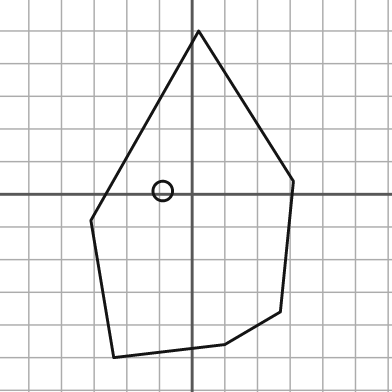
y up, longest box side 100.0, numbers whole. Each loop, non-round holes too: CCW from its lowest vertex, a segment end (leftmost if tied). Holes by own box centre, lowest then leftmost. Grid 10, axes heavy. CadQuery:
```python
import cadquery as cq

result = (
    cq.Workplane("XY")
    .moveTo(-24.0, -50.0)
    .lineTo(10.0, -46.0)
    .lineTo(27.0, -36.0)
    .lineTo(31.0, 4.0)
    .lineTo(2.0, 50.0)
    .lineTo(-31.0, -8.0)
    .close()
    .moveTo(-9.0, 1.0)
    .circle(3.0)
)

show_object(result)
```